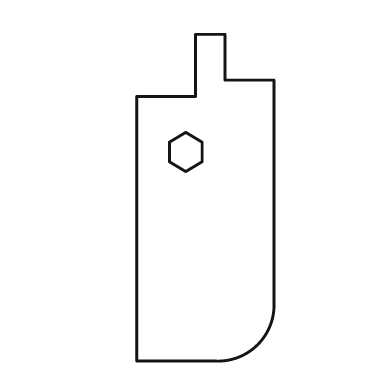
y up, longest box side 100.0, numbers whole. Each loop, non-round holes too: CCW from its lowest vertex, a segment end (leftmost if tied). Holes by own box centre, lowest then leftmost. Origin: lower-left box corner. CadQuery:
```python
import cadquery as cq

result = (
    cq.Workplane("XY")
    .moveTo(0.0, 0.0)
    .lineTo(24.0, 0.0)
    .threePointArc((37.0, 5.0), (42.0, 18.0))
    .lineTo(42.0, 86.0)
    .lineTo(27.0, 86.0)
    .lineTo(27.0, 100.0)
    .lineTo(18.0, 100.0)
    .lineTo(18.0, 81.0)
    .lineTo(0.0, 81.0)
    .close()
    .moveTo(15.0, 58.0)
    .lineTo(20.0, 61.0)
    .lineTo(20.0, 67.0)
    .lineTo(15.0, 70.0)
    .lineTo(10.0, 67.0)
    .lineTo(10.0, 61.0)
    .close()
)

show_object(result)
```